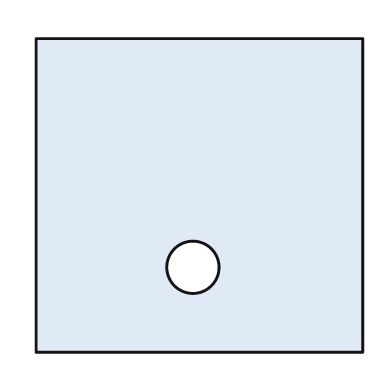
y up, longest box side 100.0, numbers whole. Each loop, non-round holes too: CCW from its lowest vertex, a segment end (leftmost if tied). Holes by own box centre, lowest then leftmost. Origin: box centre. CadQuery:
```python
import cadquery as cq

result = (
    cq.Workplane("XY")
    .moveTo(-50.0, -48.0)
    .lineTo(50.0, -48.0)
    .lineTo(50.0, 48.0)
    .lineTo(-50.0, 48.0)
    .close()
    .moveTo(-2.0, -22.0)
    .circle(8.0)
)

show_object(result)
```